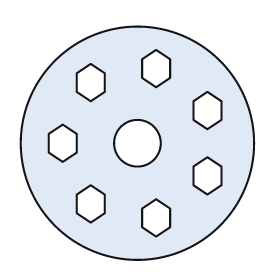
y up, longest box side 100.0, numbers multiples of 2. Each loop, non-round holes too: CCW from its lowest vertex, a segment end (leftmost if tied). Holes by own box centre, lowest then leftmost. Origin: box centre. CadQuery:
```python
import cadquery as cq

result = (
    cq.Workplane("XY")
    .moveTo(0.0, 0.0)
    .circle(50.0)
    .moveTo(8.0, -40.0)
    .lineTo(14.0, -36.0)
    .lineTo(14.0, -28.0)
    .lineTo(8.0, -24.0)
    .lineTo(2.0, -28.0)
    .lineTo(2.0, -36.0)
    .close()
    .moveTo(-20.0, -34.0)
    .lineTo(-14.0, -30.0)
    .lineTo(-14.0, -22.0)
    .lineTo(-20.0, -18.0)
    .lineTo(-26.0, -22.0)
    .lineTo(-26.0, -30.0)
    .close()
    .moveTo(30.0, -22.0)
    .lineTo(36.0, -18.0)
    .lineTo(36.0, -10.0)
    .lineTo(30.0, -6.0)
    .lineTo(24.0, -10.0)
    .lineTo(24.0, -18.0)
    .close()
    .moveTo(-32.0, -8.0)
    .lineTo(-26.0, -4.0)
    .lineTo(-26.0, 4.0)
    .lineTo(-32.0, 8.0)
    .lineTo(-38.0, 4.0)
    .lineTo(-38.0, -4.0)
    .close()
    .moveTo(0.0, 0.0)
    .circle(10.0)
    .moveTo(30.0, 6.0)
    .lineTo(36.0, 10.0)
    .lineTo(36.0, 18.0)
    .lineTo(30.0, 22.0)
    .lineTo(24.0, 18.0)
    .lineTo(24.0, 10.0)
    .close()
    .moveTo(-20.0, 18.0)
    .lineTo(-14.0, 22.0)
    .lineTo(-14.0, 30.0)
    .lineTo(-20.0, 34.0)
    .lineTo(-26.0, 30.0)
    .lineTo(-26.0, 22.0)
    .close()
    .moveTo(8.0, 24.0)
    .lineTo(14.0, 28.0)
    .lineTo(14.0, 36.0)
    .lineTo(8.0, 40.0)
    .lineTo(2.0, 36.0)
    .lineTo(2.0, 28.0)
    .close()
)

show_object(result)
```